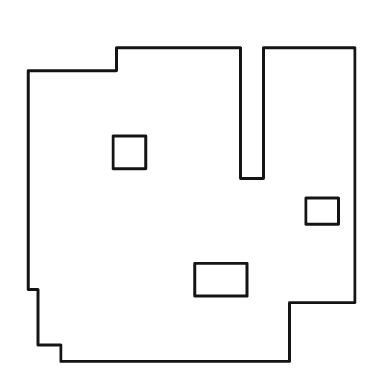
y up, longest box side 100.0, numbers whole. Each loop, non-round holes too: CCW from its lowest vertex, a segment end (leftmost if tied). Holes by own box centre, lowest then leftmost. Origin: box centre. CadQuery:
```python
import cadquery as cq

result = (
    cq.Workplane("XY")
    .moveTo(-40.0, -48.0)
    .lineTo(30.0, -48.0)
    .lineTo(30.0, -30.0)
    .lineTo(50.0, -30.0)
    .lineTo(50.0, 48.0)
    .lineTo(22.0, 48.0)
    .lineTo(22.0, 8.0)
    .lineTo(15.0, 8.0)
    .lineTo(15.0, 48.0)
    .lineTo(-23.0, 48.0)
    .lineTo(-23.0, 41.0)
    .lineTo(-50.0, 41.0)
    .lineTo(-50.0, -26.0)
    .lineTo(-47.0, -26.0)
    .lineTo(-47.0, -43.0)
    .lineTo(-40.0, -43.0)
    .close()
    .moveTo(1.0, -28.0)
    .lineTo(17.0, -28.0)
    .lineTo(17.0, -18.0)
    .lineTo(1.0, -18.0)
    .close()
    .moveTo(35.0, -6.0)
    .lineTo(45.0, -6.0)
    .lineTo(45.0, 2.0)
    .lineTo(35.0, 2.0)
    .close()
    .moveTo(-24.0, 11.0)
    .lineTo(-14.0, 11.0)
    .lineTo(-14.0, 21.0)
    .lineTo(-24.0, 21.0)
    .close()
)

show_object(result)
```